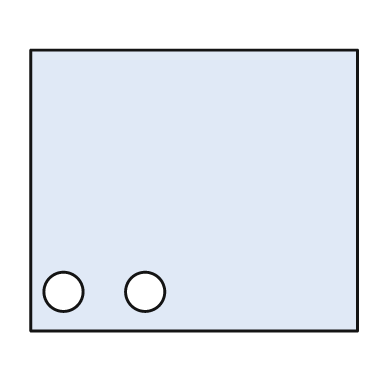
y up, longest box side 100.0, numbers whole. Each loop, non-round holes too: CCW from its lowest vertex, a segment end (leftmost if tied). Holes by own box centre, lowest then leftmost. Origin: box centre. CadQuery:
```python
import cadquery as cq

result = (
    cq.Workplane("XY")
    .moveTo(-50.0, -43.0)
    .lineTo(50.0, -43.0)
    .lineTo(50.0, 43.0)
    .lineTo(-50.0, 43.0)
    .close()
    .moveTo(-40.0, -31.0)
    .circle(6.0)
    .moveTo(-15.0, -31.0)
    .circle(6.0)
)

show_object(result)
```